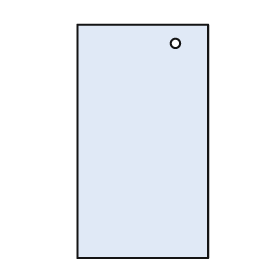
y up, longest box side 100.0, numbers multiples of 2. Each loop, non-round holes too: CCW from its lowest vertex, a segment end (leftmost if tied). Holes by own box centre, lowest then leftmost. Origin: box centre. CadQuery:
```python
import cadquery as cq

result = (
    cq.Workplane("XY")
    .moveTo(-28.0, -50.0)
    .lineTo(28.0, -50.0)
    .lineTo(28.0, 50.0)
    .lineTo(-28.0, 50.0)
    .close()
    .moveTo(14.0, 42.0)
    .circle(2.0)
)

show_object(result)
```